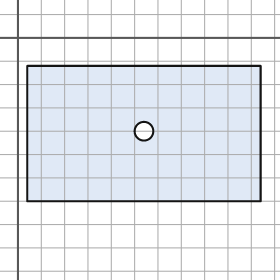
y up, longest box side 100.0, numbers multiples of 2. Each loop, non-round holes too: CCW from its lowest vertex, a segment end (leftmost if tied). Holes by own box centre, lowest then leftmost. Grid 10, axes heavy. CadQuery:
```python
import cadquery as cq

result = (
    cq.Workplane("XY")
    .moveTo(4.0, -70.0)
    .lineTo(104.0, -70.0)
    .lineTo(104.0, -12.0)
    .lineTo(4.0, -12.0)
    .close()
    .moveTo(54.0, -40.0)
    .circle(4.0)
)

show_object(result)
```